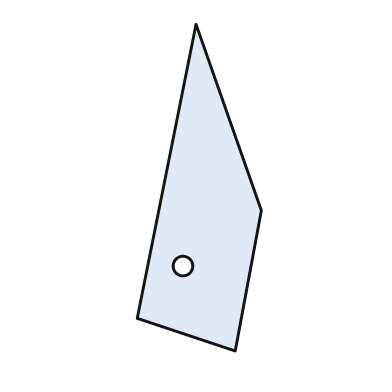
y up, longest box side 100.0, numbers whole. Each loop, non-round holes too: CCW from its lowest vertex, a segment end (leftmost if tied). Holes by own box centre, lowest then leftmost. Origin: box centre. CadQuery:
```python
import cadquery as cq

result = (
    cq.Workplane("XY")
    .moveTo(11.0, -50.0)
    .lineTo(19.0, -7.0)
    .lineTo(-1.0, 50.0)
    .lineTo(-19.0, -40.0)
    .close()
    .moveTo(-5.0, -24.0)
    .circle(3.0)
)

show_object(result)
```